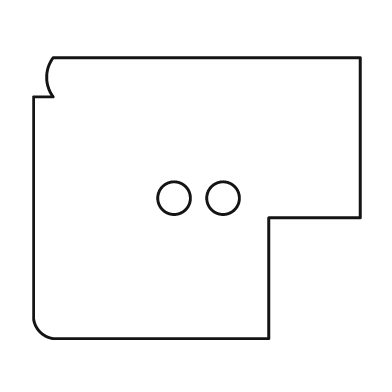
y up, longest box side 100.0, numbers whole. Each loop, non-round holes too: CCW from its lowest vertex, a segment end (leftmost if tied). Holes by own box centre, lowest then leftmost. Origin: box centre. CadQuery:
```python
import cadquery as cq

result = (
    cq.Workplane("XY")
    .moveTo(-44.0, -43.0)
    .lineTo(22.0, -43.0)
    .lineTo(22.0, -6.0)
    .lineTo(50.0, -6.0)
    .lineTo(50.0, 43.0)
    .lineTo(-44.0, 43.0)
    .threePointArc((-46.0, 37.0), (-44.0, 31.0))
    .lineTo(-50.0, 31.0)
    .lineTo(-50.0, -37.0)
    .threePointArc((-48.0, -41.0), (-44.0, -43.0))
    .close()
    .moveTo(-7.0, 0.0)
    .circle(5.0)
    .moveTo(8.0, 0.0)
    .circle(5.0)
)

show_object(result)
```